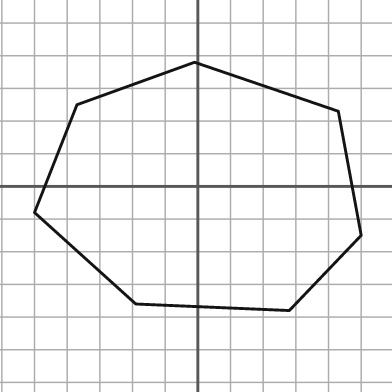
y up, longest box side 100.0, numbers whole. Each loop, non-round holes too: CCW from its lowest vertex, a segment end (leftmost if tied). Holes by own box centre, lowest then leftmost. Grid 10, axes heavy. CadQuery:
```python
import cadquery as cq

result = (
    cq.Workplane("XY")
    .moveTo(28.0, -38.0)
    .lineTo(50.0, -15.0)
    .lineTo(43.0, 23.0)
    .lineTo(-1.0, 38.0)
    .lineTo(-37.0, 25.0)
    .lineTo(-50.0, -8.0)
    .lineTo(-19.0, -36.0)
    .close()
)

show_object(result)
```